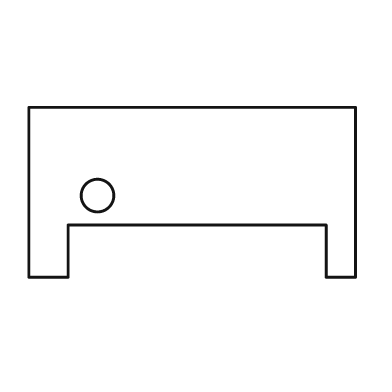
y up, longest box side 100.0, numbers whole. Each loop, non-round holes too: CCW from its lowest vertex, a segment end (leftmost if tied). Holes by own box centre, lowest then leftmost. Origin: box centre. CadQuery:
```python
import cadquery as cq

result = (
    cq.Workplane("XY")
    .moveTo(-50.0, -26.0)
    .lineTo(-38.0, -26.0)
    .lineTo(-38.0, -10.0)
    .lineTo(41.0, -10.0)
    .lineTo(41.0, -26.0)
    .lineTo(50.0, -26.0)
    .lineTo(50.0, 26.0)
    .lineTo(-50.0, 26.0)
    .close()
    .moveTo(-29.0, -1.0)
    .circle(5.0)
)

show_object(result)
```